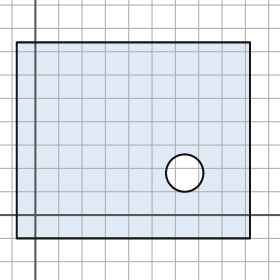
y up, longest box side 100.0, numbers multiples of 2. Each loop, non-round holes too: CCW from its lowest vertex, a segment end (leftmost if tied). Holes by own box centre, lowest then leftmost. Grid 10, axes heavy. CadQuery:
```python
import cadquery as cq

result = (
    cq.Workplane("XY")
    .moveTo(-8.0, -10.0)
    .lineTo(92.0, -10.0)
    .lineTo(92.0, 74.0)
    .lineTo(-8.0, 74.0)
    .close()
    .moveTo(64.0, 18.0)
    .circle(8.0)
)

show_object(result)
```